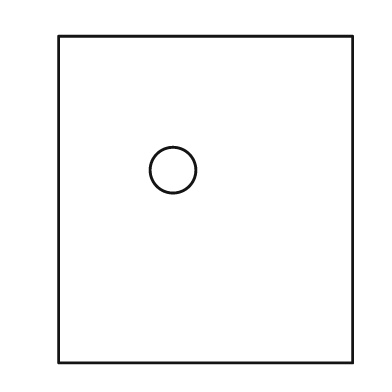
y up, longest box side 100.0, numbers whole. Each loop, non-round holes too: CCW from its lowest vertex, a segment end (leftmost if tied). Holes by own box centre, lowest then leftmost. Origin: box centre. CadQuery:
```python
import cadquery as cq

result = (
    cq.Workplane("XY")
    .moveTo(-45.0, -50.0)
    .lineTo(45.0, -50.0)
    .lineTo(45.0, 50.0)
    .lineTo(-45.0, 50.0)
    .close()
    .moveTo(-10.0, 9.0)
    .circle(7.0)
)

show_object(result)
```